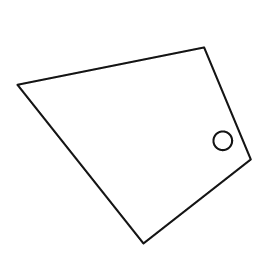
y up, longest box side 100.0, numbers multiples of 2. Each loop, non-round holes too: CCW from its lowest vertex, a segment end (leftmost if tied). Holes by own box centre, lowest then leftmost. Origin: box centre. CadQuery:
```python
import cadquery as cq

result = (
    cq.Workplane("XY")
    .moveTo(4.0, -42.0)
    .lineTo(50.0, -6.0)
    .lineTo(30.0, 42.0)
    .lineTo(-50.0, 26.0)
    .close()
    .moveTo(38.0, 2.0)
    .circle(4.0)
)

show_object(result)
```